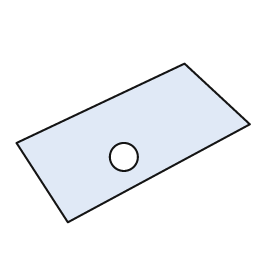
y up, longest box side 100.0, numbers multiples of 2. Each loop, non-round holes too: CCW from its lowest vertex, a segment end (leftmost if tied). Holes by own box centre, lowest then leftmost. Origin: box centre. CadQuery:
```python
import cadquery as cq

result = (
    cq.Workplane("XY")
    .moveTo(-28.0, -34.0)
    .lineTo(50.0, 8.0)
    .lineTo(22.0, 34.0)
    .lineTo(-50.0, 0.0)
    .close()
    .moveTo(-4.0, -6.0)
    .circle(6.0)
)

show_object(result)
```